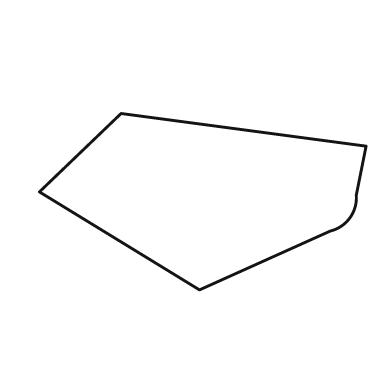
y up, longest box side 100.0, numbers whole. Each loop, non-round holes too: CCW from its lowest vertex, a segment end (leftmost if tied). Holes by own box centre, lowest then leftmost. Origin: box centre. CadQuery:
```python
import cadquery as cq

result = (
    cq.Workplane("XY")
    .moveTo(-1.0, -27.0)
    .lineTo(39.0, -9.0)
    .threePointArc((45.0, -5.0), (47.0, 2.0))
    .lineTo(50.0, 17.0)
    .lineTo(-25.0, 27.0)
    .lineTo(-50.0, 3.0)
    .close()
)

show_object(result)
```